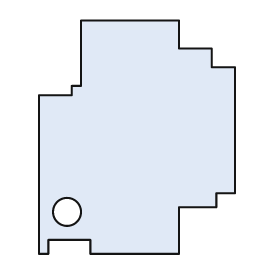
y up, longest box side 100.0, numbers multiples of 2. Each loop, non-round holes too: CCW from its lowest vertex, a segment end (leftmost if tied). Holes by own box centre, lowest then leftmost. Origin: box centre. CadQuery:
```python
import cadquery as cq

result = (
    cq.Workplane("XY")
    .moveTo(-42.0, -50.0)
    .lineTo(-38.0, -50.0)
    .lineTo(-38.0, -44.0)
    .lineTo(-20.0, -44.0)
    .lineTo(-20.0, -50.0)
    .lineTo(18.0, -50.0)
    .lineTo(18.0, -30.0)
    .lineTo(34.0, -30.0)
    .lineTo(34.0, -24.0)
    .lineTo(42.0, -24.0)
    .lineTo(42.0, 30.0)
    .lineTo(32.0, 30.0)
    .lineTo(32.0, 38.0)
    .lineTo(18.0, 38.0)
    .lineTo(18.0, 50.0)
    .lineTo(-24.0, 50.0)
    .lineTo(-24.0, 22.0)
    .lineTo(-28.0, 22.0)
    .lineTo(-28.0, 18.0)
    .lineTo(-42.0, 18.0)
    .close()
    .moveTo(-30.0, -32.0)
    .circle(6.0)
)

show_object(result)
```